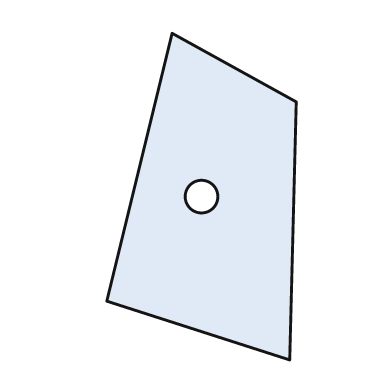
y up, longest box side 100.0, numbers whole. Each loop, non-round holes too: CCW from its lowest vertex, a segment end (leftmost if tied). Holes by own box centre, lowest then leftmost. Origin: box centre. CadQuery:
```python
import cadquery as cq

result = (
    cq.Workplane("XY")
    .moveTo(27.0, -50.0)
    .lineTo(29.0, 29.0)
    .lineTo(-9.0, 50.0)
    .lineTo(-29.0, -32.0)
    .close()
    .moveTo(0.0, 0.0)
    .circle(5.0)
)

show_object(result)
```